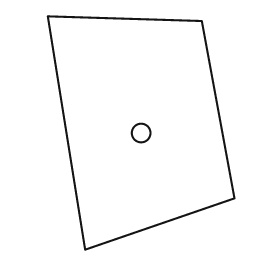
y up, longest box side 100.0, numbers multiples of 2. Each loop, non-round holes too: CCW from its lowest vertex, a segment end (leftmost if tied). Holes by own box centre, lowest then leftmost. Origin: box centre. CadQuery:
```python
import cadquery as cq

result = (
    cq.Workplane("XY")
    .moveTo(-24.0, -50.0)
    .lineTo(40.0, -28.0)
    .lineTo(26.0, 48.0)
    .lineTo(-40.0, 50.0)
    .close()
    .moveTo(0.0, 0.0)
    .circle(4.0)
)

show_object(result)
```